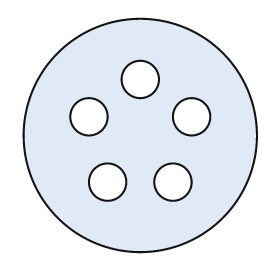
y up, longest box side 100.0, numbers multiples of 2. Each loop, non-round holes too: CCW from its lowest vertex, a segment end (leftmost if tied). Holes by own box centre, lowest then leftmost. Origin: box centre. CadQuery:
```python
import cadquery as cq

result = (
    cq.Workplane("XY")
    .moveTo(0.0, 0.0)
    .circle(50.0)
    .moveTo(-14.0, -20.0)
    .circle(8.0)
    .moveTo(14.0, -20.0)
    .circle(8.0)
    .moveTo(-22.0, 8.0)
    .circle(8.0)
    .moveTo(22.0, 8.0)
    .circle(8.0)
    .moveTo(0.0, 24.0)
    .circle(8.0)
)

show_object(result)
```